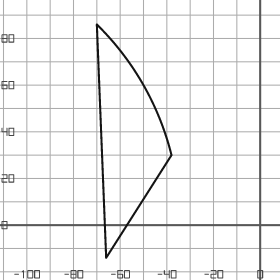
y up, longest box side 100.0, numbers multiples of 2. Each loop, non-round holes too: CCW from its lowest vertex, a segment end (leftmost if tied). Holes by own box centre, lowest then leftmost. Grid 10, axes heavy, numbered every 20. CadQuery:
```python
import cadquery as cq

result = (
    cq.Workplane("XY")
    .moveTo(-66.0, -14.0)
    .lineTo(-38.0, 30.0)
    .threePointArc((-50.0, 60.0), (-70.0, 86.0))
    .close()
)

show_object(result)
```